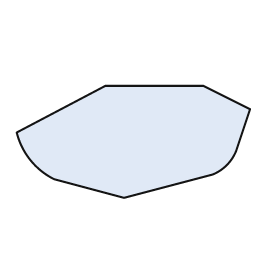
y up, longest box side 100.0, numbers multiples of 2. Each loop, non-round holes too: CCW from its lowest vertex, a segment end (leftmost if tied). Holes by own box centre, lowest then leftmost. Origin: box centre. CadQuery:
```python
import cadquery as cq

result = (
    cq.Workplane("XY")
    .moveTo(-4.0, -24.0)
    .lineTo(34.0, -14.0)
    .threePointArc((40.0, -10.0), (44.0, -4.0))
    .lineTo(50.0, 14.0)
    .lineTo(30.0, 24.0)
    .lineTo(-12.0, 24.0)
    .lineTo(-50.0, 4.0)
    .threePointArc((-44.0, -8.0), (-34.0, -16.0))
    .close()
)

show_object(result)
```